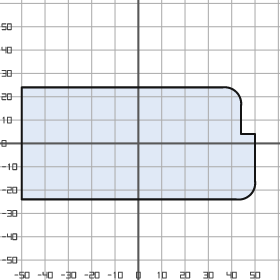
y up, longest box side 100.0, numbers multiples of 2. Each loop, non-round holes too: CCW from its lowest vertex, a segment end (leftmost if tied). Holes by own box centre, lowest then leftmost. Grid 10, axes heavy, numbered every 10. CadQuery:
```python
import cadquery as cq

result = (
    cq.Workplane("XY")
    .moveTo(-50.0, -24.0)
    .lineTo(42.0, -24.0)
    .threePointArc((48.0, -22.0), (50.0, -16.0))
    .lineTo(50.0, 4.0)
    .lineTo(44.0, 4.0)
    .lineTo(44.0, 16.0)
    .threePointArc((42.0, 22.0), (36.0, 24.0))
    .lineTo(-50.0, 24.0)
    .close()
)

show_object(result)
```